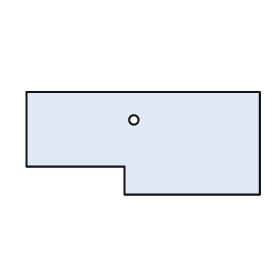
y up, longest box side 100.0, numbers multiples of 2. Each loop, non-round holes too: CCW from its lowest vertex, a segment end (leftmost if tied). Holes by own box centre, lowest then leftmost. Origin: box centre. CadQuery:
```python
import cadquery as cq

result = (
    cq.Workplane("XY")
    .moveTo(-8.0, -22.0)
    .lineTo(50.0, -22.0)
    .lineTo(50.0, 22.0)
    .lineTo(-50.0, 22.0)
    .lineTo(-50.0, -10.0)
    .lineTo(-8.0, -10.0)
    .close()
    .moveTo(-4.0, 10.0)
    .circle(2.0)
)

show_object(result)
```